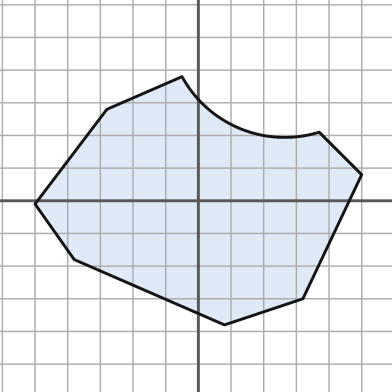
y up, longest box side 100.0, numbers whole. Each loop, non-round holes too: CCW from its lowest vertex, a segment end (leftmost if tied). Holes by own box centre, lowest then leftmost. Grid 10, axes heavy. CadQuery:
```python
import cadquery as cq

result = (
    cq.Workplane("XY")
    .moveTo(8.0, -38.0)
    .lineTo(32.0, -30.0)
    .lineTo(50.0, 8.0)
    .lineTo(37.0, 21.0)
    .threePointArc((13.0, 22.0), (-5.0, 38.0))
    .lineTo(-28.0, 28.0)
    .lineTo(-50.0, -1.0)
    .lineTo(-38.0, -18.0)
    .close()
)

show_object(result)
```